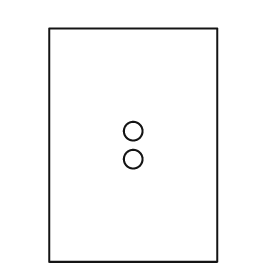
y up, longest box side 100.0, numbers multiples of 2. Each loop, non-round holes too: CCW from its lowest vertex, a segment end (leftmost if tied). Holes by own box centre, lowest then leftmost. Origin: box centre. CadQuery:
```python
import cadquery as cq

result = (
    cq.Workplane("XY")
    .moveTo(-36.0, -50.0)
    .lineTo(36.0, -50.0)
    .lineTo(36.0, 50.0)
    .lineTo(-36.0, 50.0)
    .close()
    .moveTo(0.0, -6.0)
    .circle(4.0)
    .moveTo(0.0, 6.0)
    .circle(4.0)
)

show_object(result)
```